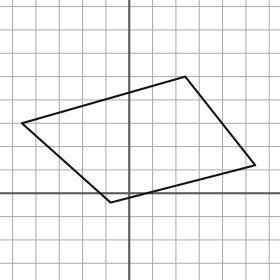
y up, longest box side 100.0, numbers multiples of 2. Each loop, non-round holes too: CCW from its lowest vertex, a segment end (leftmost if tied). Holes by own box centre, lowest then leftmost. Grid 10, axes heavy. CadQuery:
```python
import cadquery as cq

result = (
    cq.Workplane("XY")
    .moveTo(-8.0, -4.0)
    .lineTo(54.0, 12.0)
    .lineTo(24.0, 50.0)
    .lineTo(-46.0, 30.0)
    .close()
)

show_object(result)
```